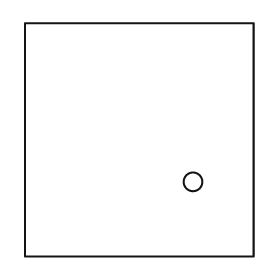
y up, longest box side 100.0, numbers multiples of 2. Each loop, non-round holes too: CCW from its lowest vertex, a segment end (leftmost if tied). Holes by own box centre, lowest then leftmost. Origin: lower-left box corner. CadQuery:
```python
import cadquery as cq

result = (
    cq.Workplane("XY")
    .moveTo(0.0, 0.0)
    .lineTo(98.0, 0.0)
    .lineTo(98.0, 100.0)
    .lineTo(0.0, 100.0)
    .close()
    .moveTo(72.0, 32.0)
    .circle(4.0)
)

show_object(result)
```